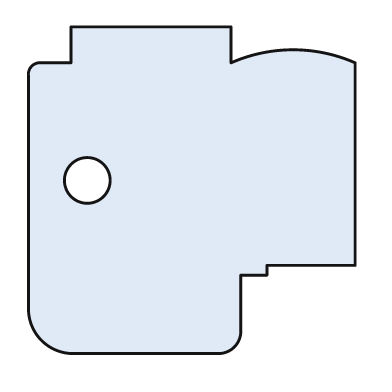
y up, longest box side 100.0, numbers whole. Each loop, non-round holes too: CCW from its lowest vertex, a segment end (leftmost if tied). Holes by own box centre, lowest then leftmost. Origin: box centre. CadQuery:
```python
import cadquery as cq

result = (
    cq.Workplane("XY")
    .moveTo(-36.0, -50.0)
    .lineTo(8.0, -50.0)
    .threePointArc((13.0, -48.0), (15.0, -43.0))
    .lineTo(15.0, -26.0)
    .lineTo(23.0, -26.0)
    .lineTo(23.0, -23.0)
    .lineTo(50.0, -23.0)
    .lineTo(50.0, 39.0)
    .threePointArc((31.0, 43.0), (12.0, 39.0))
    .lineTo(12.0, 50.0)
    .lineTo(-37.0, 50.0)
    .lineTo(-37.0, 39.0)
    .lineTo(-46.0, 39.0)
    .threePointArc((-49.0, 38.0), (-50.0, 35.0))
    .lineTo(-50.0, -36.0)
    .threePointArc((-46.0, -46.0), (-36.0, -50.0))
    .close()
    .moveTo(-32.0, 3.0)
    .circle(7.0)
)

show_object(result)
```